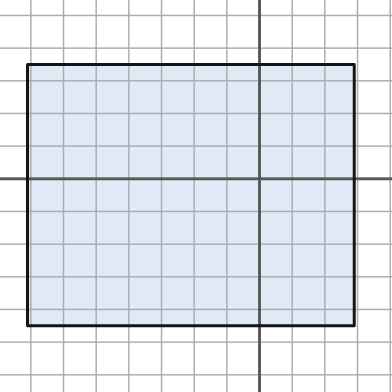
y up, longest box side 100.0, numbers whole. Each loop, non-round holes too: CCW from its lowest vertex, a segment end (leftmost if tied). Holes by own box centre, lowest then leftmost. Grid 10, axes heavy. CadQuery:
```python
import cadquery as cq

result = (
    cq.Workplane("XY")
    .moveTo(-71.0, -45.0)
    .lineTo(29.0, -45.0)
    .lineTo(29.0, 35.0)
    .lineTo(-71.0, 35.0)
    .close()
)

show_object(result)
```